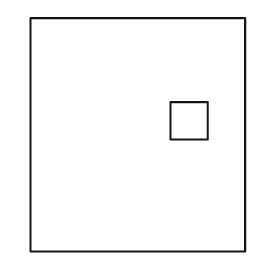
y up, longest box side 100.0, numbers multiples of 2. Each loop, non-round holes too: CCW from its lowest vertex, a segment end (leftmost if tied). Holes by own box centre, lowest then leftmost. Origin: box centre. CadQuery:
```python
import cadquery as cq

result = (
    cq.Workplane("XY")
    .moveTo(-46.0, -50.0)
    .lineTo(46.0, -50.0)
    .lineTo(46.0, 50.0)
    .lineTo(-46.0, 50.0)
    .close()
    .moveTo(14.0, -2.0)
    .lineTo(30.0, -2.0)
    .lineTo(30.0, 14.0)
    .lineTo(14.0, 14.0)
    .close()
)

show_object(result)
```